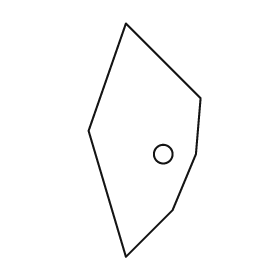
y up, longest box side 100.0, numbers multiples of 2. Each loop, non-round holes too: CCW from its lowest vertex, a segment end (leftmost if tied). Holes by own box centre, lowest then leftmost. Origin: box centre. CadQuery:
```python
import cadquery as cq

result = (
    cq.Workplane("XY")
    .moveTo(-8.0, -50.0)
    .lineTo(12.0, -30.0)
    .lineTo(22.0, -6.0)
    .lineTo(24.0, 18.0)
    .lineTo(-8.0, 50.0)
    .lineTo(-24.0, 4.0)
    .close()
    .moveTo(8.0, -6.0)
    .circle(4.0)
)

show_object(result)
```